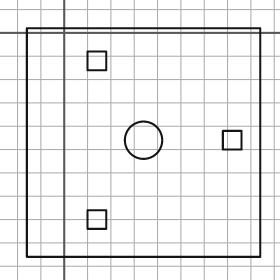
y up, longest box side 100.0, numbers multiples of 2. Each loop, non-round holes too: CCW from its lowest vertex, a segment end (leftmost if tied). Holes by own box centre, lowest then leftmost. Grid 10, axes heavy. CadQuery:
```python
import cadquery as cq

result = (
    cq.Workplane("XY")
    .moveTo(-16.0, -96.0)
    .lineTo(84.0, -96.0)
    .lineTo(84.0, 2.0)
    .lineTo(-16.0, 2.0)
    .close()
    .moveTo(10.0, -84.0)
    .lineTo(18.0, -84.0)
    .lineTo(18.0, -76.0)
    .lineTo(10.0, -76.0)
    .close()
    .moveTo(34.0, -46.0)
    .circle(8.0)
    .moveTo(68.0, -50.0)
    .lineTo(76.0, -50.0)
    .lineTo(76.0, -42.0)
    .lineTo(68.0, -42.0)
    .close()
    .moveTo(10.0, -16.0)
    .lineTo(18.0, -16.0)
    .lineTo(18.0, -8.0)
    .lineTo(10.0, -8.0)
    .close()
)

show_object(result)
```